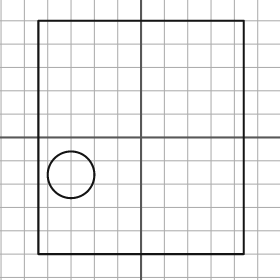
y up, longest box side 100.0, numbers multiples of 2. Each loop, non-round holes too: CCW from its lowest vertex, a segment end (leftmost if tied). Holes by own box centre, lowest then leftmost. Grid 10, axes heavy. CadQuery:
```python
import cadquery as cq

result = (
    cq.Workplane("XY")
    .moveTo(-44.0, -50.0)
    .lineTo(44.0, -50.0)
    .lineTo(44.0, 50.0)
    .lineTo(-44.0, 50.0)
    .close()
    .moveTo(-30.0, -16.0)
    .circle(10.0)
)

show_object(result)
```